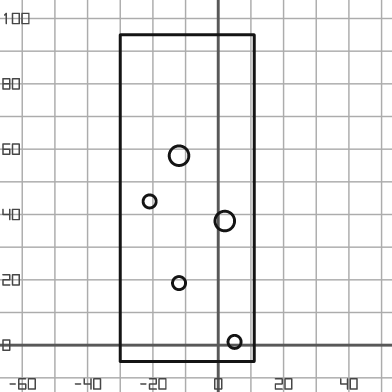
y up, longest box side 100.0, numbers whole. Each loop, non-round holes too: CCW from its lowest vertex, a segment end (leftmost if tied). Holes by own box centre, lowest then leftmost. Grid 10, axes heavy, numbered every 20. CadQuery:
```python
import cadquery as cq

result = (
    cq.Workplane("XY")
    .moveTo(-30.0, -5.0)
    .lineTo(11.0, -5.0)
    .lineTo(11.0, 95.0)
    .lineTo(-30.0, 95.0)
    .close()
    .moveTo(5.0, 1.0)
    .circle(2.0)
    .moveTo(-12.0, 19.0)
    .circle(2.0)
    .moveTo(2.0, 38.0)
    .circle(3.0)
    .moveTo(-21.0, 44.0)
    .circle(2.0)
    .moveTo(-12.0, 58.0)
    .circle(3.0)
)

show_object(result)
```